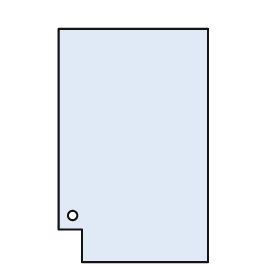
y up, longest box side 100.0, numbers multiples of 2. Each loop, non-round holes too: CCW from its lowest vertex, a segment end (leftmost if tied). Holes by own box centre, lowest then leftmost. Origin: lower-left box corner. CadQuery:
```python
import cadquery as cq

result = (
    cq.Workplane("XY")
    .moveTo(10.0, 0.0)
    .lineTo(64.0, 0.0)
    .lineTo(64.0, 100.0)
    .lineTo(0.0, 100.0)
    .lineTo(0.0, 14.0)
    .lineTo(10.0, 14.0)
    .close()
    .moveTo(6.0, 20.0)
    .circle(2.0)
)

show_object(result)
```